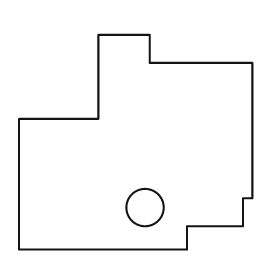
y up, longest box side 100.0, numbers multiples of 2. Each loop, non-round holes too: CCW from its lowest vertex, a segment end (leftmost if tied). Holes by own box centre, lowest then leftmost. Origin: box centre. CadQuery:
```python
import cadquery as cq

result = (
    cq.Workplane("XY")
    .moveTo(-50.0, -46.0)
    .lineTo(22.0, -46.0)
    .lineTo(22.0, -36.0)
    .lineTo(46.0, -36.0)
    .lineTo(46.0, -24.0)
    .lineTo(50.0, -24.0)
    .lineTo(50.0, 34.0)
    .lineTo(6.0, 34.0)
    .lineTo(6.0, 46.0)
    .lineTo(-16.0, 46.0)
    .lineTo(-16.0, 10.0)
    .lineTo(-50.0, 10.0)
    .close()
    .moveTo(4.0, -28.0)
    .circle(8.0)
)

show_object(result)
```